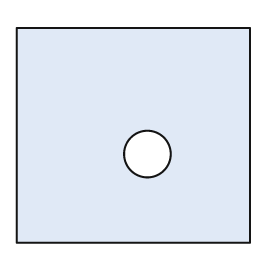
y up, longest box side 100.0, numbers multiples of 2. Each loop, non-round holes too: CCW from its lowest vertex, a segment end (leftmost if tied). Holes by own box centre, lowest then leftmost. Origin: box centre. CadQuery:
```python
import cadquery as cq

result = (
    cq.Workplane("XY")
    .moveTo(-50.0, -46.0)
    .lineTo(50.0, -46.0)
    .lineTo(50.0, 46.0)
    .lineTo(-50.0, 46.0)
    .close()
    .moveTo(6.0, -8.0)
    .circle(10.0)
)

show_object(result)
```